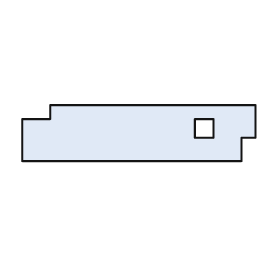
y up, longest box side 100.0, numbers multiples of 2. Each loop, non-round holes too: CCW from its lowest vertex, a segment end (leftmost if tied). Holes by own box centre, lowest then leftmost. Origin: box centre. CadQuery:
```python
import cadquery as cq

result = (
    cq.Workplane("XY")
    .moveTo(-50.0, -12.0)
    .lineTo(44.0, -12.0)
    .lineTo(44.0, -2.0)
    .lineTo(50.0, -2.0)
    .lineTo(50.0, 12.0)
    .lineTo(-38.0, 12.0)
    .lineTo(-38.0, 6.0)
    .lineTo(-50.0, 6.0)
    .close()
    .moveTo(24.0, -2.0)
    .lineTo(32.0, -2.0)
    .lineTo(32.0, 6.0)
    .lineTo(24.0, 6.0)
    .close()
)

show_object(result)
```